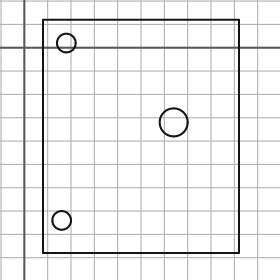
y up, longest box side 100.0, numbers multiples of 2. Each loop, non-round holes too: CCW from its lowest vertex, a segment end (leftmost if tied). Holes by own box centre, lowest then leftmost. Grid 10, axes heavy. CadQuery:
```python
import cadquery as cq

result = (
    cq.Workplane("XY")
    .moveTo(8.0, -88.0)
    .lineTo(92.0, -88.0)
    .lineTo(92.0, 12.0)
    .lineTo(8.0, 12.0)
    .close()
    .moveTo(16.0, -74.0)
    .circle(4.0)
    .moveTo(64.0, -32.0)
    .circle(6.0)
    .moveTo(18.0, 2.0)
    .circle(4.0)
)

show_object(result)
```